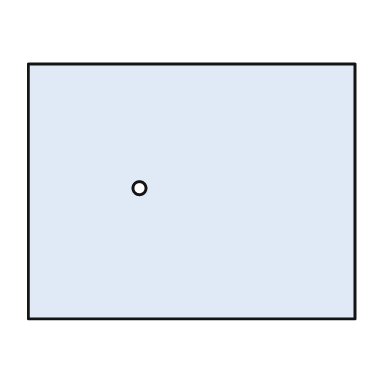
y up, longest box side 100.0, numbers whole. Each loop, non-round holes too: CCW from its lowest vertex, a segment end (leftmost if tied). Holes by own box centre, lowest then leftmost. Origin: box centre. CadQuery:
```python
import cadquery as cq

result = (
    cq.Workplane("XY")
    .moveTo(-50.0, -39.0)
    .lineTo(50.0, -39.0)
    .lineTo(50.0, 39.0)
    .lineTo(-50.0, 39.0)
    .close()
    .moveTo(-16.0, 1.0)
    .circle(2.0)
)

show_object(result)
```